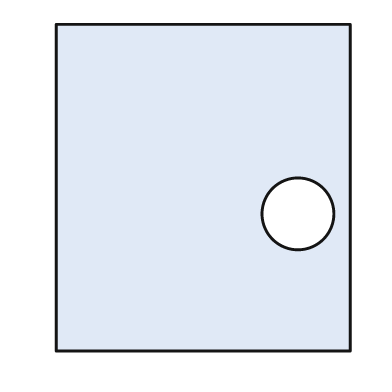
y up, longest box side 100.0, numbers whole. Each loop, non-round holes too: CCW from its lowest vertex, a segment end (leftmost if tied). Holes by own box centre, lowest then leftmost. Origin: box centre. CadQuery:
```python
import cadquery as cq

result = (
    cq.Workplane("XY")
    .moveTo(-45.0, -50.0)
    .lineTo(45.0, -50.0)
    .lineTo(45.0, 50.0)
    .lineTo(-45.0, 50.0)
    .close()
    .moveTo(29.0, -8.0)
    .circle(11.0)
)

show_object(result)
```